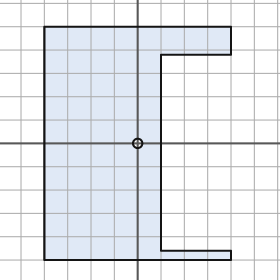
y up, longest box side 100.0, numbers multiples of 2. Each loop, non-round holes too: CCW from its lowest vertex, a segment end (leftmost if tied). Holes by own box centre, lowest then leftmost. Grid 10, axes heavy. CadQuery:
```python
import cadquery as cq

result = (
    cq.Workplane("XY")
    .moveTo(-40.0, -50.0)
    .lineTo(40.0, -50.0)
    .lineTo(40.0, -46.0)
    .lineTo(10.0, -46.0)
    .lineTo(10.0, 38.0)
    .lineTo(40.0, 38.0)
    .lineTo(40.0, 50.0)
    .lineTo(-40.0, 50.0)
    .close()
    .moveTo(0.0, 0.0)
    .circle(2.0)
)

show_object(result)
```